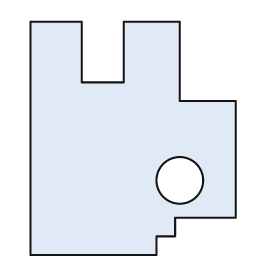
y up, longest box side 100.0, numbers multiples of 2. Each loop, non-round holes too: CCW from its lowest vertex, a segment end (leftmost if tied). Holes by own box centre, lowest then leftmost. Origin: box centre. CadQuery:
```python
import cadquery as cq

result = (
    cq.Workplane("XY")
    .moveTo(-44.0, -50.0)
    .lineTo(10.0, -50.0)
    .lineTo(10.0, -42.0)
    .lineTo(18.0, -42.0)
    .lineTo(18.0, -34.0)
    .lineTo(44.0, -34.0)
    .lineTo(44.0, 16.0)
    .lineTo(20.0, 16.0)
    .lineTo(20.0, 50.0)
    .lineTo(-4.0, 50.0)
    .lineTo(-4.0, 24.0)
    .lineTo(-22.0, 24.0)
    .lineTo(-22.0, 50.0)
    .lineTo(-44.0, 50.0)
    .close()
    .moveTo(20.0, -18.0)
    .circle(10.0)
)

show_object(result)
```